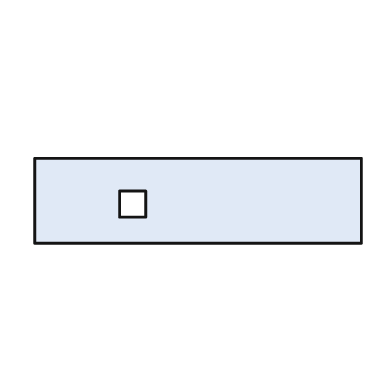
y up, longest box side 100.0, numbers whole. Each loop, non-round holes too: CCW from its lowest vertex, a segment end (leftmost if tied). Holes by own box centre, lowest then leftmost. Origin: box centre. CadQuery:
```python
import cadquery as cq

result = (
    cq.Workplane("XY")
    .moveTo(-50.0, -13.0)
    .lineTo(50.0, -13.0)
    .lineTo(50.0, 13.0)
    .lineTo(-50.0, 13.0)
    .close()
    .moveTo(-24.0, -5.0)
    .lineTo(-16.0, -5.0)
    .lineTo(-16.0, 3.0)
    .lineTo(-24.0, 3.0)
    .close()
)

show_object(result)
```